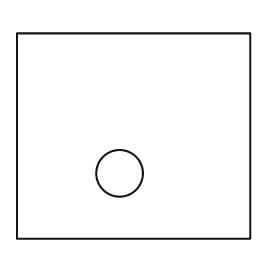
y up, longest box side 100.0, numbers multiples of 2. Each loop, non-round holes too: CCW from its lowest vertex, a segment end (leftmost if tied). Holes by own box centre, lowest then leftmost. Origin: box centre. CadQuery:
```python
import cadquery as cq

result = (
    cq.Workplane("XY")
    .moveTo(-50.0, -44.0)
    .lineTo(50.0, -44.0)
    .lineTo(50.0, 44.0)
    .lineTo(-50.0, 44.0)
    .close()
    .moveTo(-6.0, -16.0)
    .circle(10.0)
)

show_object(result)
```